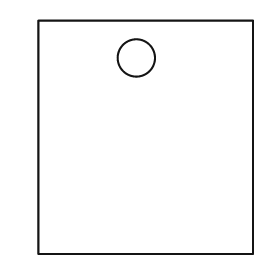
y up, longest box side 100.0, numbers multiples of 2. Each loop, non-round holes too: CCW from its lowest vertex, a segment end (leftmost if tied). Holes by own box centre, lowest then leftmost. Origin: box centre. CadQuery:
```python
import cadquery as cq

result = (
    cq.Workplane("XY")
    .moveTo(-46.0, -50.0)
    .lineTo(46.0, -50.0)
    .lineTo(46.0, 50.0)
    .lineTo(-46.0, 50.0)
    .close()
    .moveTo(-4.0, 34.0)
    .circle(8.0)
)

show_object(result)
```